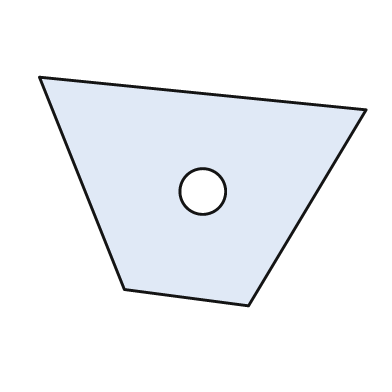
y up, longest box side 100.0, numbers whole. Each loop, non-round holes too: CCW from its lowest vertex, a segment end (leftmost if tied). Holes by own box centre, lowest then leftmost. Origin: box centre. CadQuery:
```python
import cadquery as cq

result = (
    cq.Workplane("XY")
    .moveTo(14.0, -35.0)
    .lineTo(50.0, 25.0)
    .lineTo(-50.0, 35.0)
    .lineTo(-24.0, -30.0)
    .close()
    .moveTo(0.0, 0.0)
    .circle(7.0)
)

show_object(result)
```